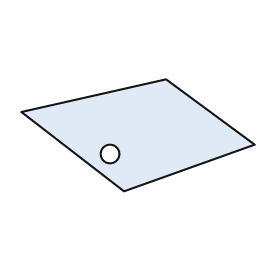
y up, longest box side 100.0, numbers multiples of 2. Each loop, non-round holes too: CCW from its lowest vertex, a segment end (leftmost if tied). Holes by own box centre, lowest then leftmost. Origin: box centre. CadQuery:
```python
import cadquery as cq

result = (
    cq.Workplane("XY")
    .moveTo(-6.0, -24.0)
    .lineTo(50.0, -4.0)
    .lineTo(12.0, 24.0)
    .lineTo(-50.0, 10.0)
    .close()
    .moveTo(-12.0, -8.0)
    .circle(4.0)
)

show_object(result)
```